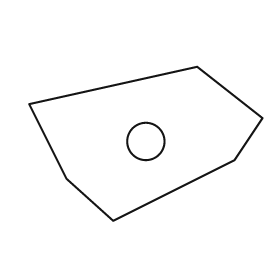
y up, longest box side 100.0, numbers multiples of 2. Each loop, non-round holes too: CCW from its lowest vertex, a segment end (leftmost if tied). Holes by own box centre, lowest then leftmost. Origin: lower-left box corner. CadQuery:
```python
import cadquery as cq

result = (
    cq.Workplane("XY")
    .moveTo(36.0, 0.0)
    .lineTo(88.0, 26.0)
    .lineTo(100.0, 44.0)
    .lineTo(72.0, 66.0)
    .lineTo(0.0, 50.0)
    .lineTo(16.0, 18.0)
    .close()
    .moveTo(50.0, 34.0)
    .circle(8.0)
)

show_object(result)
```